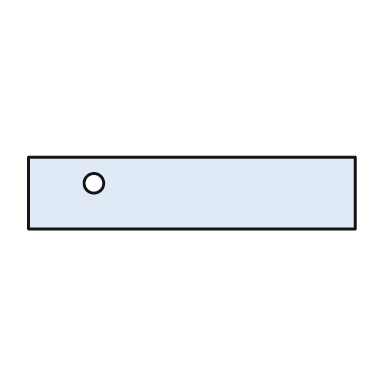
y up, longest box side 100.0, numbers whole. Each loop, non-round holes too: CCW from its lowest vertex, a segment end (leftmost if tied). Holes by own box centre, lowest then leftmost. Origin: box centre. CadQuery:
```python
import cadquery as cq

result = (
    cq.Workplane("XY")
    .moveTo(-50.0, -11.0)
    .lineTo(50.0, -11.0)
    .lineTo(50.0, 11.0)
    .lineTo(-50.0, 11.0)
    .close()
    .moveTo(-30.0, 3.0)
    .circle(3.0)
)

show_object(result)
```